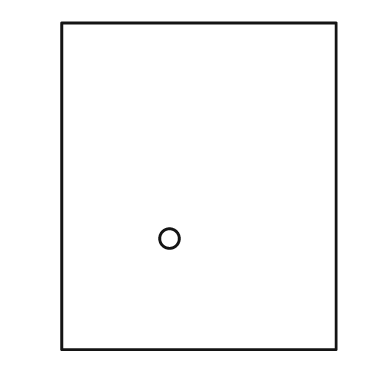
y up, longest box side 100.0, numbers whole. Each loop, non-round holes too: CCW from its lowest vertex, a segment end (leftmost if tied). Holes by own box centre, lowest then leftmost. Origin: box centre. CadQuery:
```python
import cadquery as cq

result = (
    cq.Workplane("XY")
    .moveTo(-42.0, -50.0)
    .lineTo(42.0, -50.0)
    .lineTo(42.0, 50.0)
    .lineTo(-42.0, 50.0)
    .close()
    .moveTo(-9.0, -16.0)
    .circle(3.0)
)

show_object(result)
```